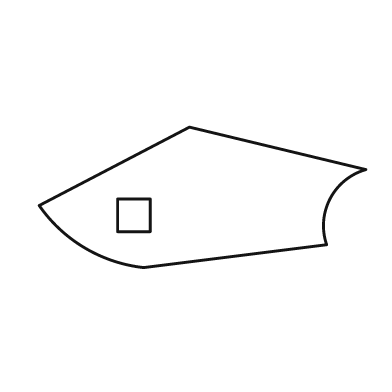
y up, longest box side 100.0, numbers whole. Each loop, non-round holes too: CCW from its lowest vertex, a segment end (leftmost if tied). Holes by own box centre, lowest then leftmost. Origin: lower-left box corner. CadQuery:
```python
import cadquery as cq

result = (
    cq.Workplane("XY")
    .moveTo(32.0, 0.0)
    .lineTo(88.0, 7.0)
    .threePointArc((89.0, 21.0), (100.0, 30.0))
    .lineTo(46.0, 43.0)
    .lineTo(0.0, 19.0)
    .threePointArc((14.0, 6.0), (32.0, 0.0))
    .close()
    .moveTo(24.0, 11.0)
    .lineTo(34.0, 11.0)
    .lineTo(34.0, 21.0)
    .lineTo(24.0, 21.0)
    .close()
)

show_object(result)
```